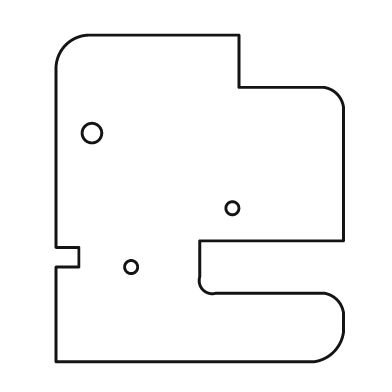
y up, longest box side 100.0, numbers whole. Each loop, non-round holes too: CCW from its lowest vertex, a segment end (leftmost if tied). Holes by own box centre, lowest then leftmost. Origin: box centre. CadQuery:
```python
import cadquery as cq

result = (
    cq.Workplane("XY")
    .moveTo(-44.0, -50.0)
    .lineTo(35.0, -50.0)
    .threePointArc((41.0, -47.0), (44.0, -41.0))
    .lineTo(44.0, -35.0)
    .threePointArc((42.0, -31.0), (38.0, -29.0))
    .lineTo(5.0, -29.0)
    .threePointArc((1.0, -28.0), (0.0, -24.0))
    .lineTo(0.0, -13.0)
    .lineTo(44.0, -13.0)
    .lineTo(44.0, 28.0)
    .threePointArc((42.0, 32.0), (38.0, 34.0))
    .lineTo(12.0, 34.0)
    .lineTo(12.0, 50.0)
    .lineTo(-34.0, 50.0)
    .threePointArc((-41.0, 47.0), (-44.0, 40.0))
    .lineTo(-44.0, -15.0)
    .lineTo(-37.0, -15.0)
    .lineTo(-37.0, -21.0)
    .lineTo(-44.0, -21.0)
    .close()
    .moveTo(-21.0, -21.0)
    .circle(2.0)
    .moveTo(10.0, -3.0)
    .circle(2.0)
    .moveTo(-33.0, 20.0)
    .circle(3.0)
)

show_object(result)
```